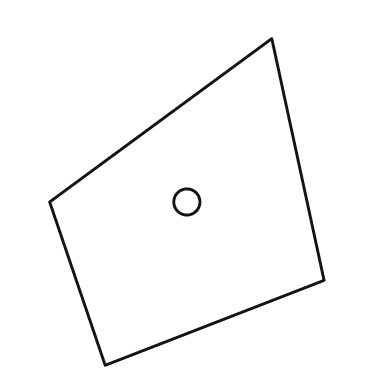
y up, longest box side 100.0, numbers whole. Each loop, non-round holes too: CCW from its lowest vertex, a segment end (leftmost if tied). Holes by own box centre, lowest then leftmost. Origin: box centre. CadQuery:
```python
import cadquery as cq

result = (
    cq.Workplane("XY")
    .moveTo(-25.0, -50.0)
    .lineTo(42.0, -24.0)
    .lineTo(26.0, 50.0)
    .lineTo(-42.0, 0.0)
    .close()
    .moveTo(0.0, 0.0)
    .circle(4.0)
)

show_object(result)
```